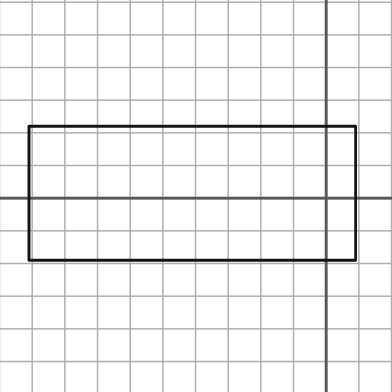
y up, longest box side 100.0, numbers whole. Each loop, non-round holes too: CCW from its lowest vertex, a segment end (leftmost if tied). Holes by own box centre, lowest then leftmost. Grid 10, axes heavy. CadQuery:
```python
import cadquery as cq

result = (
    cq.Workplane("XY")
    .moveTo(-91.0, -19.0)
    .lineTo(9.0, -19.0)
    .lineTo(9.0, 22.0)
    .lineTo(-91.0, 22.0)
    .close()
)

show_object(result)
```